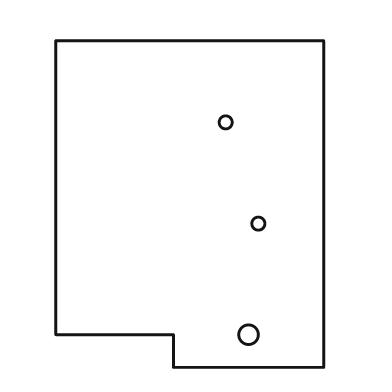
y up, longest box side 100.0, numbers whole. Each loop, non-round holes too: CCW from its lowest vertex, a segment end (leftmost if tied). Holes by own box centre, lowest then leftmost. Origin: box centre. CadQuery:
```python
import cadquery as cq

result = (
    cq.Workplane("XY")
    .moveTo(-5.0, -50.0)
    .lineTo(41.0, -50.0)
    .lineTo(41.0, 50.0)
    .lineTo(-41.0, 50.0)
    .lineTo(-41.0, -40.0)
    .lineTo(-5.0, -40.0)
    .close()
    .moveTo(18.0, -40.0)
    .circle(3.0)
    .moveTo(21.0, -6.0)
    .circle(2.0)
    .moveTo(11.0, 25.0)
    .circle(2.0)
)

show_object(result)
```